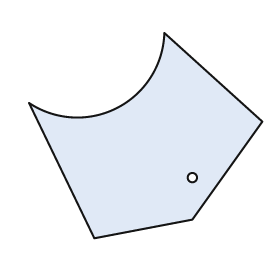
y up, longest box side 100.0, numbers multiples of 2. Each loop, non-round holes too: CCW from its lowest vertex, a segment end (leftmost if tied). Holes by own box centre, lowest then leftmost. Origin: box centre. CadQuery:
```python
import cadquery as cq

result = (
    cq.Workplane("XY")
    .moveTo(-22.0, -44.0)
    .lineTo(20.0, -36.0)
    .lineTo(50.0, 6.0)
    .lineTo(8.0, 44.0)
    .threePointArc((-12.0, 12.0), (-50.0, 14.0))
    .close()
    .moveTo(20.0, -18.0)
    .circle(2.0)
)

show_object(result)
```